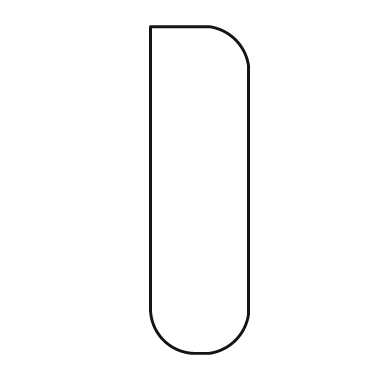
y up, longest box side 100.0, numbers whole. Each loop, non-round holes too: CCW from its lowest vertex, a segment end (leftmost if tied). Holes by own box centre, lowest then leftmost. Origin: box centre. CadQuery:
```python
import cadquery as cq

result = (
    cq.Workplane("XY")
    .moveTo(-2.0, -50.0)
    .lineTo(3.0, -50.0)
    .threePointArc((11.0, -46.0), (15.0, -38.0))
    .lineTo(15.0, 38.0)
    .threePointArc((11.0, 46.0), (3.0, 50.0))
    .lineTo(-15.0, 50.0)
    .lineTo(-15.0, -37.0)
    .threePointArc((-11.0, -46.0), (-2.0, -50.0))
    .close()
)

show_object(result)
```